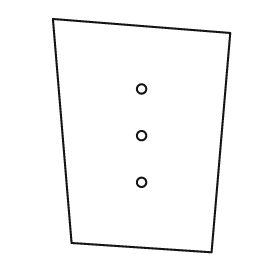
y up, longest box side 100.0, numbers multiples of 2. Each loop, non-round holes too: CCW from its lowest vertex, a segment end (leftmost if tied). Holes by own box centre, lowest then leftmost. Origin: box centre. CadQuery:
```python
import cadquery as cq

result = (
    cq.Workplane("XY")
    .moveTo(30.0, -50.0)
    .lineTo(38.0, 44.0)
    .lineTo(-38.0, 50.0)
    .lineTo(-30.0, -46.0)
    .close()
    .moveTo(0.0, -20.0)
    .circle(2.0)
    .moveTo(0.0, 0.0)
    .circle(2.0)
    .moveTo(0.0, 20.0)
    .circle(2.0)
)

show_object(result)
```